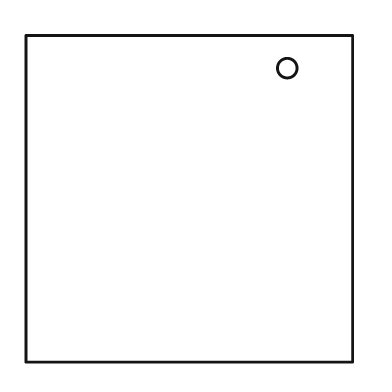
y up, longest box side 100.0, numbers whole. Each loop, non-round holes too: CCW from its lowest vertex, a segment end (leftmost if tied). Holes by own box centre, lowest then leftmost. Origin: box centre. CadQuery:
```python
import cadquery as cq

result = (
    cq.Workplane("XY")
    .moveTo(-50.0, -50.0)
    .lineTo(50.0, -50.0)
    .lineTo(50.0, 50.0)
    .lineTo(-50.0, 50.0)
    .close()
    .moveTo(30.0, 40.0)
    .circle(3.0)
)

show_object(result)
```